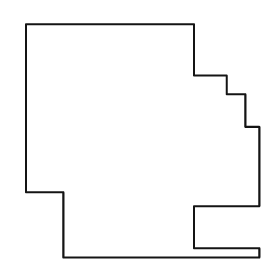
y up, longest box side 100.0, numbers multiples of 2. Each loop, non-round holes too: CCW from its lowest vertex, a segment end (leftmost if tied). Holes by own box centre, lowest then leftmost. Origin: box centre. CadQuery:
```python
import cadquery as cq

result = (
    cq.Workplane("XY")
    .moveTo(-34.0, -50.0)
    .lineTo(50.0, -50.0)
    .lineTo(50.0, -46.0)
    .lineTo(22.0, -46.0)
    .lineTo(22.0, -28.0)
    .lineTo(50.0, -28.0)
    .lineTo(50.0, 6.0)
    .lineTo(44.0, 6.0)
    .lineTo(44.0, 20.0)
    .lineTo(36.0, 20.0)
    .lineTo(36.0, 28.0)
    .lineTo(22.0, 28.0)
    .lineTo(22.0, 50.0)
    .lineTo(-50.0, 50.0)
    .lineTo(-50.0, -22.0)
    .lineTo(-34.0, -22.0)
    .close()
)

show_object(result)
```